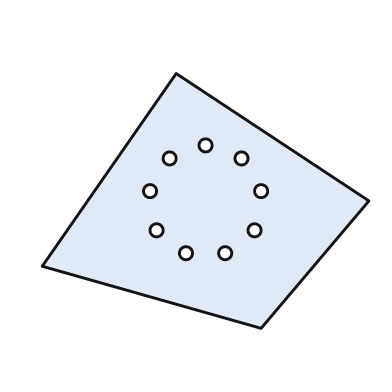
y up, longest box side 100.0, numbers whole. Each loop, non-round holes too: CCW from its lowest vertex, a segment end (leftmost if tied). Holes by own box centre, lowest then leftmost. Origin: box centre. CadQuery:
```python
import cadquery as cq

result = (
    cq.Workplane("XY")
    .moveTo(17.0, -39.0)
    .lineTo(50.0, 0.0)
    .lineTo(-9.0, 39.0)
    .lineTo(-50.0, -20.0)
    .close()
    .moveTo(-6.0, -16.0)
    .circle(2.0)
    .moveTo(6.0, -16.0)
    .circle(2.0)
    .moveTo(-15.0, -9.0)
    .circle(2.0)
    .moveTo(15.0, -9.0)
    .circle(2.0)
    .moveTo(-17.0, 3.0)
    .circle(2.0)
    .moveTo(17.0, 3.0)
    .circle(2.0)
    .moveTo(-11.0, 13.0)
    .circle(2.0)
    .moveTo(11.0, 13.0)
    .circle(2.0)
    .moveTo(0.0, 17.0)
    .circle(2.0)
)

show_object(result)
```